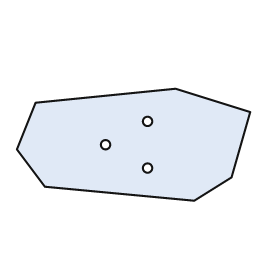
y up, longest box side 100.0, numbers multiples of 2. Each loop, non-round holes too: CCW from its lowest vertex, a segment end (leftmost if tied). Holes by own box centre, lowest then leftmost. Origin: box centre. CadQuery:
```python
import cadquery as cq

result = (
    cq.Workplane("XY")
    .moveTo(26.0, -24.0)
    .lineTo(42.0, -14.0)
    .lineTo(50.0, 14.0)
    .lineTo(18.0, 24.0)
    .lineTo(-42.0, 18.0)
    .lineTo(-50.0, -2.0)
    .lineTo(-38.0, -18.0)
    .close()
    .moveTo(6.0, -10.0)
    .circle(2.0)
    .moveTo(-12.0, 0.0)
    .circle(2.0)
    .moveTo(6.0, 10.0)
    .circle(2.0)
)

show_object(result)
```